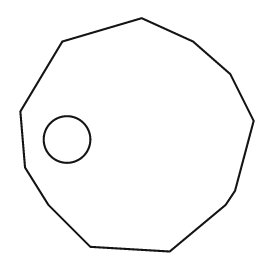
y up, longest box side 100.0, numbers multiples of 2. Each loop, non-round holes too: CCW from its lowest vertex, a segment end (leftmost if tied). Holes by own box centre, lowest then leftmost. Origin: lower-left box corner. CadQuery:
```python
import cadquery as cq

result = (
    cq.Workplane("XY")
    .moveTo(64.0, 0.0)
    .lineTo(88.0, 20.0)
    .lineTo(92.0, 26.0)
    .lineTo(100.0, 56.0)
    .lineTo(90.0, 76.0)
    .lineTo(74.0, 90.0)
    .lineTo(52.0, 100.0)
    .lineTo(18.0, 90.0)
    .lineTo(0.0, 60.0)
    .lineTo(2.0, 36.0)
    .lineTo(12.0, 20.0)
    .lineTo(30.0, 2.0)
    .close()
    .moveTo(20.0, 48.0)
    .circle(10.0)
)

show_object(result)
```